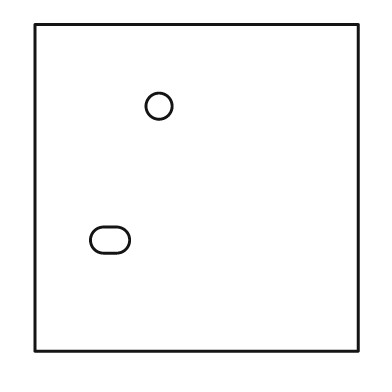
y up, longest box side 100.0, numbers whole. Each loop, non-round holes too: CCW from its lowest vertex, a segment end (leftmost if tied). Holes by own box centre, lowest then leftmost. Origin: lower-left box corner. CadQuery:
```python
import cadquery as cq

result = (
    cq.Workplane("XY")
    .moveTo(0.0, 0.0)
    .lineTo(99.0, 0.0)
    .lineTo(99.0, 100.0)
    .lineTo(0.0, 100.0)
    .close()
    .moveTo(21.0, 30.0)
    .lineTo(25.0, 30.0)
    .threePointArc((29.0, 34.0), (25.0, 38.0))
    .lineTo(21.0, 38.0)
    .threePointArc((17.0, 34.0), (21.0, 30.0))
    .close()
    .moveTo(38.0, 75.0)
    .circle(4.0)
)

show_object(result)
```